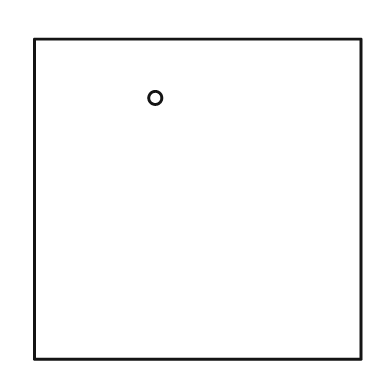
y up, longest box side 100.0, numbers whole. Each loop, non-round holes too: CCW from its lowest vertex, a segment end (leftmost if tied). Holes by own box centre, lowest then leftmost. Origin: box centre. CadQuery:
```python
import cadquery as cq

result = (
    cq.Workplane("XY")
    .moveTo(-50.0, -49.0)
    .lineTo(50.0, -49.0)
    .lineTo(50.0, 49.0)
    .lineTo(-50.0, 49.0)
    .close()
    .moveTo(-13.0, 31.0)
    .circle(2.0)
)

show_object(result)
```